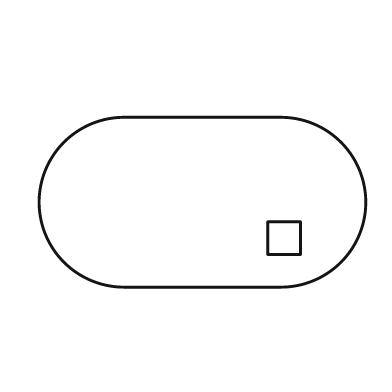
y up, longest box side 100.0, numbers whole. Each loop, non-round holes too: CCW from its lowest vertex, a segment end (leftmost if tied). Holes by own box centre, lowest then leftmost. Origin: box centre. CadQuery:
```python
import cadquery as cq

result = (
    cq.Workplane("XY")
    .moveTo(-24.0, -26.0)
    .lineTo(24.0, -26.0)
    .threePointArc((50.0, 0.0), (24.0, 26.0))
    .lineTo(-24.0, 26.0)
    .threePointArc((-50.0, 0.0), (-24.0, -26.0))
    .close()
    .moveTo(20.0, -16.0)
    .lineTo(30.0, -16.0)
    .lineTo(30.0, -6.0)
    .lineTo(20.0, -6.0)
    .close()
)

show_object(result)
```